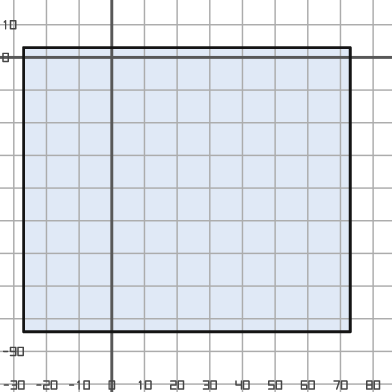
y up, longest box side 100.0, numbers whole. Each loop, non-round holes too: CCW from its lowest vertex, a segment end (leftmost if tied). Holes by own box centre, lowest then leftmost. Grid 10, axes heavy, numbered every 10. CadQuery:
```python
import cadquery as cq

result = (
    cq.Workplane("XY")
    .moveTo(-27.0, -84.0)
    .lineTo(73.0, -84.0)
    .lineTo(73.0, 3.0)
    .lineTo(-27.0, 3.0)
    .close()
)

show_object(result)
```